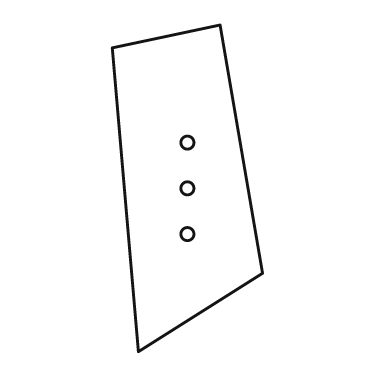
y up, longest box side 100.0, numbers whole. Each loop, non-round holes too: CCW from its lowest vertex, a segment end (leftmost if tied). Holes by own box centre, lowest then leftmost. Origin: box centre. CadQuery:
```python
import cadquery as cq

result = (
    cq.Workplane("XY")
    .moveTo(-15.0, -50.0)
    .lineTo(23.0, -26.0)
    .lineTo(10.0, 50.0)
    .lineTo(-23.0, 43.0)
    .close()
    .moveTo(0.0, -14.0)
    .circle(2.0)
    .moveTo(0.0, 0.0)
    .circle(2.0)
    .moveTo(0.0, 14.0)
    .circle(2.0)
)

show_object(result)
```